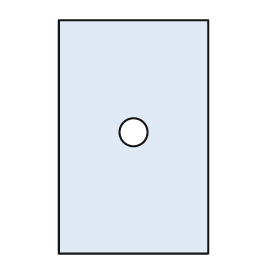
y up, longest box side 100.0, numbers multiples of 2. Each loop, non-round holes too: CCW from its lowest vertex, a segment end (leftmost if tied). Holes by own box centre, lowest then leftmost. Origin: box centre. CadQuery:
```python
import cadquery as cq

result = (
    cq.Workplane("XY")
    .moveTo(-32.0, -50.0)
    .lineTo(32.0, -50.0)
    .lineTo(32.0, 50.0)
    .lineTo(-32.0, 50.0)
    .close()
    .moveTo(0.0, 2.0)
    .circle(6.0)
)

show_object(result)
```